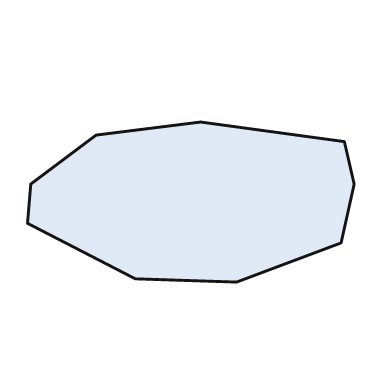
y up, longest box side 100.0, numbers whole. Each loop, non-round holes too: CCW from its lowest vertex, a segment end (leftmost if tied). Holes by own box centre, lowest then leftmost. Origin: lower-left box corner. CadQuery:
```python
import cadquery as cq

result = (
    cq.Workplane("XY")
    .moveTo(64.0, 0.0)
    .lineTo(96.0, 12.0)
    .lineTo(100.0, 30.0)
    .lineTo(97.0, 43.0)
    .lineTo(53.0, 49.0)
    .lineTo(21.0, 45.0)
    .lineTo(1.0, 30.0)
    .lineTo(0.0, 18.0)
    .lineTo(33.0, 1.0)
    .close()
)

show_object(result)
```